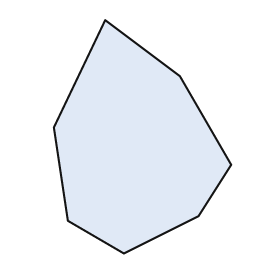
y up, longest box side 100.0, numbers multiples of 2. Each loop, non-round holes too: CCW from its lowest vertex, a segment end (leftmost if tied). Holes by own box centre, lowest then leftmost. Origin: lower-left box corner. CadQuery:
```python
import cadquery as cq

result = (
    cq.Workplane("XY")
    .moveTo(30.0, 0.0)
    .lineTo(62.0, 16.0)
    .lineTo(76.0, 38.0)
    .lineTo(54.0, 76.0)
    .lineTo(22.0, 100.0)
    .lineTo(0.0, 54.0)
    .lineTo(6.0, 14.0)
    .close()
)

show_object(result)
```